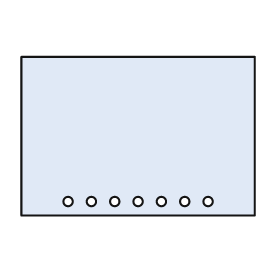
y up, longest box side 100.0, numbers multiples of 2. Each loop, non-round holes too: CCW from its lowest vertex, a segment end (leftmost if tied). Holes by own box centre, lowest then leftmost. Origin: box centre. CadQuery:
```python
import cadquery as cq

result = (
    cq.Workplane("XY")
    .moveTo(-50.0, -34.0)
    .lineTo(50.0, -34.0)
    .lineTo(50.0, 34.0)
    .lineTo(-50.0, 34.0)
    .close()
    .moveTo(-30.0, -28.0)
    .circle(2.0)
    .moveTo(-20.0, -28.0)
    .circle(2.0)
    .moveTo(-10.0, -28.0)
    .circle(2.0)
    .moveTo(0.0, -28.0)
    .circle(2.0)
    .moveTo(10.0, -28.0)
    .circle(2.0)
    .moveTo(20.0, -28.0)
    .circle(2.0)
    .moveTo(30.0, -28.0)
    .circle(2.0)
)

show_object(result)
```